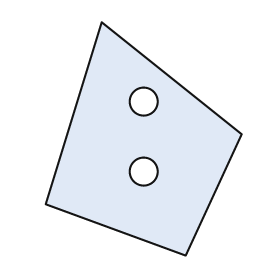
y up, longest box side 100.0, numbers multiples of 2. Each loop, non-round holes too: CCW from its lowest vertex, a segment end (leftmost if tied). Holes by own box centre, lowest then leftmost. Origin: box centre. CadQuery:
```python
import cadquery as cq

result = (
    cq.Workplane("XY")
    .moveTo(18.0, -50.0)
    .lineTo(42.0, 2.0)
    .lineTo(-18.0, 50.0)
    .lineTo(-42.0, -28.0)
    .close()
    .moveTo(0.0, -14.0)
    .circle(6.0)
    .moveTo(0.0, 16.0)
    .circle(6.0)
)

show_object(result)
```